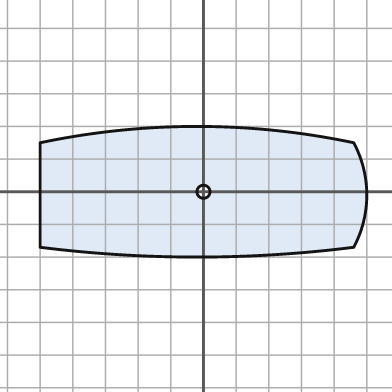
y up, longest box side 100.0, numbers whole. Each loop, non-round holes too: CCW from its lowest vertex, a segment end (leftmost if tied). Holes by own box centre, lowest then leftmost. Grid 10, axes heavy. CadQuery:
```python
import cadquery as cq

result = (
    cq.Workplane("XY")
    .moveTo(-50.0, -17.0)
    .threePointArc((-2.0, -20.0), (46.0, -17.0))
    .threePointArc((50.0, -1.0), (46.0, 15.0))
    .threePointArc((-2.0, 20.0), (-50.0, 15.0))
    .close()
    .moveTo(0.0, 0.0)
    .circle(2.0)
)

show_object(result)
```